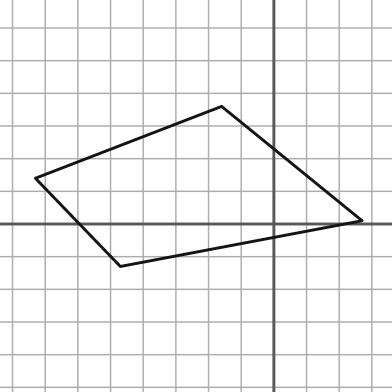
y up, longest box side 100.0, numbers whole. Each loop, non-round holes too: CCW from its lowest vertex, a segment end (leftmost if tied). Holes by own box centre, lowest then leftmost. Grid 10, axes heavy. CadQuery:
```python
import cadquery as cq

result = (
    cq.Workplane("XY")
    .moveTo(-47.0, -13.0)
    .lineTo(27.0, 1.0)
    .lineTo(-16.0, 36.0)
    .lineTo(-73.0, 14.0)
    .close()
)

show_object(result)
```